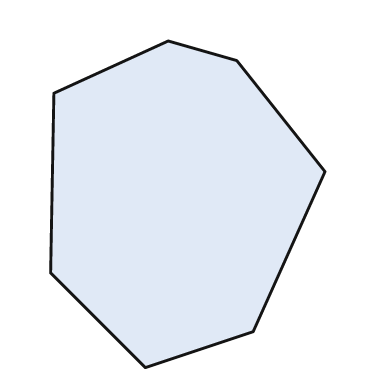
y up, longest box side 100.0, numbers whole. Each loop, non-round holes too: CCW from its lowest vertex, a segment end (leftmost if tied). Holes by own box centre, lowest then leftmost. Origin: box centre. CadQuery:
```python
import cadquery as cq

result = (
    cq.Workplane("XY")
    .moveTo(-13.0, -50.0)
    .lineTo(20.0, -39.0)
    .lineTo(42.0, 10.0)
    .lineTo(15.0, 44.0)
    .lineTo(-6.0, 50.0)
    .lineTo(-41.0, 34.0)
    .lineTo(-42.0, -21.0)
    .close()
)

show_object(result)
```